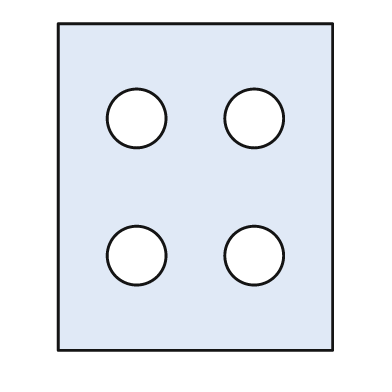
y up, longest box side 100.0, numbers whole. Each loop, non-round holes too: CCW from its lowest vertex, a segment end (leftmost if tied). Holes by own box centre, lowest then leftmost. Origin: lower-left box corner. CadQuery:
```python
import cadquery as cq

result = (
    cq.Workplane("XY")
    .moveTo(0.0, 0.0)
    .lineTo(84.0, 0.0)
    .lineTo(84.0, 100.0)
    .lineTo(0.0, 100.0)
    .close()
    .moveTo(24.0, 29.0)
    .circle(9.0)
    .moveTo(60.0, 29.0)
    .circle(9.0)
    .moveTo(24.0, 71.0)
    .circle(9.0)
    .moveTo(60.0, 71.0)
    .circle(9.0)
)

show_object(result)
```